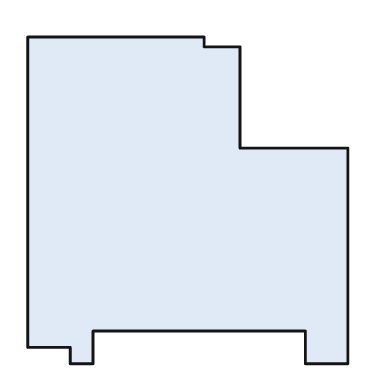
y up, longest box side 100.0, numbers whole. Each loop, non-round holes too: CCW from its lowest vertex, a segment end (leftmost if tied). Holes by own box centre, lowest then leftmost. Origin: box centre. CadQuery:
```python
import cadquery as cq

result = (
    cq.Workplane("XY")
    .moveTo(-36.0, -50.0)
    .lineTo(-29.0, -50.0)
    .lineTo(-29.0, -40.0)
    .lineTo(36.0, -40.0)
    .lineTo(36.0, -50.0)
    .lineTo(49.0, -50.0)
    .lineTo(49.0, 16.0)
    .lineTo(16.0, 16.0)
    .lineTo(16.0, 47.0)
    .lineTo(5.0, 47.0)
    .lineTo(5.0, 50.0)
    .lineTo(-49.0, 50.0)
    .lineTo(-49.0, -45.0)
    .lineTo(-36.0, -45.0)
    .close()
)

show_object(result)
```